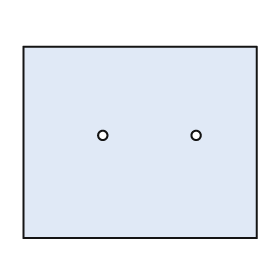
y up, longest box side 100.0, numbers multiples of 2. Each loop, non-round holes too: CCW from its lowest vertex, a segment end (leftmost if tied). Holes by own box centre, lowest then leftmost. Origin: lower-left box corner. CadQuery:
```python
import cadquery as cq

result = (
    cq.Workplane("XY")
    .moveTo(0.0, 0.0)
    .lineTo(100.0, 0.0)
    .lineTo(100.0, 82.0)
    .lineTo(0.0, 82.0)
    .close()
    .moveTo(34.0, 44.0)
    .circle(2.0)
    .moveTo(74.0, 44.0)
    .circle(2.0)
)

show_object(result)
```